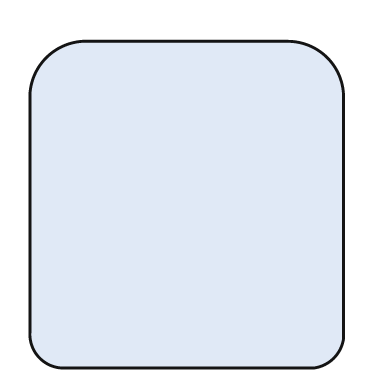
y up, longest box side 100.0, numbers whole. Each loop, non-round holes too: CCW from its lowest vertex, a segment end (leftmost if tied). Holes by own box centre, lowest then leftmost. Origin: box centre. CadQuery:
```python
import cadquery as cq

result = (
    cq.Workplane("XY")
    .moveTo(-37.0, -50.0)
    .lineTo(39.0, -50.0)
    .threePointArc((45.0, -47.0), (48.0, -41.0))
    .lineTo(48.0, 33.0)
    .threePointArc((43.0, 45.0), (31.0, 50.0))
    .lineTo(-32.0, 50.0)
    .threePointArc((-43.0, 45.0), (-48.0, 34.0))
    .lineTo(-48.0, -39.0)
    .threePointArc((-45.0, -47.0), (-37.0, -50.0))
    .close()
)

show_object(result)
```